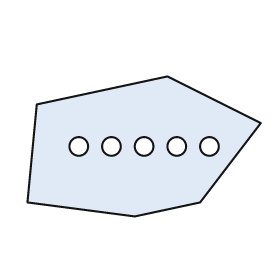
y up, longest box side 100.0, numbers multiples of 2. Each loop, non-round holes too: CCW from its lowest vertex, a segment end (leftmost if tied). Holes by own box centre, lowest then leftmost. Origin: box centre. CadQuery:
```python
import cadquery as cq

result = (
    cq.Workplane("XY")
    .moveTo(-4.0, -30.0)
    .lineTo(24.0, -24.0)
    .lineTo(50.0, 10.0)
    .lineTo(10.0, 30.0)
    .lineTo(-46.0, 18.0)
    .lineTo(-50.0, -24.0)
    .close()
    .moveTo(-28.0, 0.0)
    .circle(4.0)
    .moveTo(-14.0, 0.0)
    .circle(4.0)
    .moveTo(0.0, 0.0)
    .circle(4.0)
    .moveTo(14.0, 0.0)
    .circle(4.0)
    .moveTo(28.0, 0.0)
    .circle(4.0)
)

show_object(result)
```